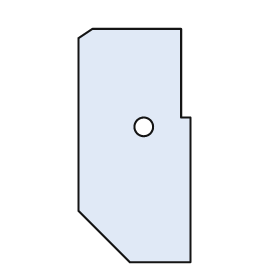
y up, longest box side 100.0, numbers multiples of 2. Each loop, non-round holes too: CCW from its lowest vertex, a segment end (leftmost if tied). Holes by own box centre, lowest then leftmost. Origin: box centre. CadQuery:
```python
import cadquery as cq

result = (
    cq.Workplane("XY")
    .moveTo(-2.0, -50.0)
    .lineTo(24.0, -50.0)
    .lineTo(24.0, 12.0)
    .lineTo(20.0, 12.0)
    .lineTo(20.0, 50.0)
    .lineTo(-18.0, 50.0)
    .lineTo(-24.0, 46.0)
    .lineTo(-24.0, -28.0)
    .close()
    .moveTo(4.0, 8.0)
    .circle(4.0)
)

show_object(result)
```